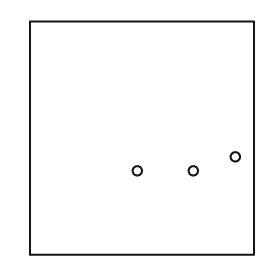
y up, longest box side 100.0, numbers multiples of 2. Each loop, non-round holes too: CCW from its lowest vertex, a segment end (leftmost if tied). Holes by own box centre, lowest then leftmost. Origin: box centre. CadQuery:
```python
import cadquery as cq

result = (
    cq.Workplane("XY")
    .moveTo(-48.0, -50.0)
    .lineTo(48.0, -50.0)
    .lineTo(48.0, 50.0)
    .lineTo(-48.0, 50.0)
    .close()
    .moveTo(-2.0, -14.0)
    .circle(2.0)
    .moveTo(22.0, -14.0)
    .circle(2.0)
    .moveTo(40.0, -8.0)
    .circle(2.0)
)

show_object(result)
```